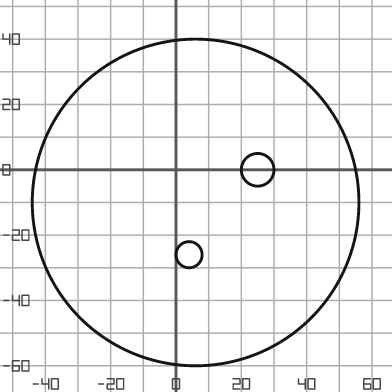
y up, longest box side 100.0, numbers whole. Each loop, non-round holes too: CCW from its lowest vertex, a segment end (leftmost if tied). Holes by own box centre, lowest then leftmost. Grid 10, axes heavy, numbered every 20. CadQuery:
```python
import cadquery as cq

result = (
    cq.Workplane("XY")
    .moveTo(6.0, -10.0)
    .circle(50.0)
    .moveTo(4.0, -26.0)
    .circle(4.0)
    .moveTo(25.0, 0.0)
    .circle(5.0)
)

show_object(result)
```